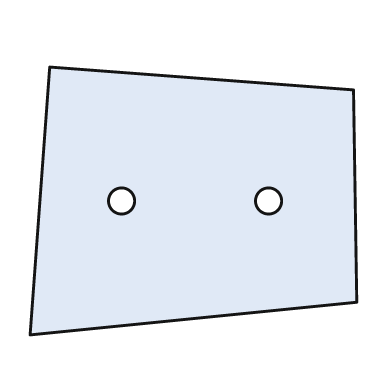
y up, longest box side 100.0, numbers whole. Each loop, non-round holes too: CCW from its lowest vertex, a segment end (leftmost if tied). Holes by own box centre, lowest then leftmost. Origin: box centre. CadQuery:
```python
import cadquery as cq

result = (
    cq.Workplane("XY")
    .moveTo(-50.0, -41.0)
    .lineTo(50.0, -31.0)
    .lineTo(49.0, 34.0)
    .lineTo(-44.0, 41.0)
    .close()
    .moveTo(-22.0, 0.0)
    .circle(4.0)
    .moveTo(23.0, 0.0)
    .circle(4.0)
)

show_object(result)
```